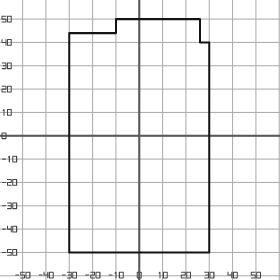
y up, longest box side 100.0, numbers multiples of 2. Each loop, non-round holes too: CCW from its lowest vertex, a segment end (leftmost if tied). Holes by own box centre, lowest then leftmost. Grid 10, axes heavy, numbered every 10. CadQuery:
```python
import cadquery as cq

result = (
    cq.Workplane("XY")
    .moveTo(-30.0, -50.0)
    .lineTo(30.0, -50.0)
    .lineTo(30.0, 40.0)
    .lineTo(26.0, 40.0)
    .lineTo(26.0, 50.0)
    .lineTo(-10.0, 50.0)
    .lineTo(-10.0, 44.0)
    .lineTo(-30.0, 44.0)
    .close()
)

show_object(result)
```